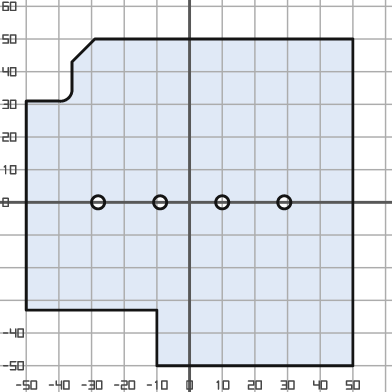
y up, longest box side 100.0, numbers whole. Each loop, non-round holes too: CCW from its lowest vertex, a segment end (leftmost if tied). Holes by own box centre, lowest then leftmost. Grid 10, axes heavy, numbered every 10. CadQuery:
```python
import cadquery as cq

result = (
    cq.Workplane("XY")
    .moveTo(-10.0, -50.0)
    .lineTo(50.0, -50.0)
    .lineTo(50.0, 50.0)
    .lineTo(-29.0, 50.0)
    .lineTo(-36.0, 43.0)
    .lineTo(-36.0, 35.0)
    .threePointArc((-37.0, 32.0), (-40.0, 31.0))
    .lineTo(-50.0, 31.0)
    .lineTo(-50.0, -33.0)
    .lineTo(-10.0, -33.0)
    .close()
    .moveTo(-28.0, 0.0)
    .circle(2.0)
    .moveTo(-9.0, 0.0)
    .circle(2.0)
    .moveTo(10.0, 0.0)
    .circle(2.0)
    .moveTo(29.0, 0.0)
    .circle(2.0)
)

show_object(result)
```